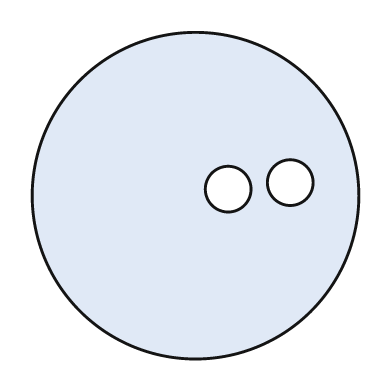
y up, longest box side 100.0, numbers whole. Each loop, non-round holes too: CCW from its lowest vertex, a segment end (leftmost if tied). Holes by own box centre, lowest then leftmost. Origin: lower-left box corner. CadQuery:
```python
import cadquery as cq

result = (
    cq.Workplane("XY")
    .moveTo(50.0, 50.0)
    .circle(50.0)
    .moveTo(60.0, 52.0)
    .circle(7.0)
    .moveTo(79.0, 54.0)
    .circle(7.0)
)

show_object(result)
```